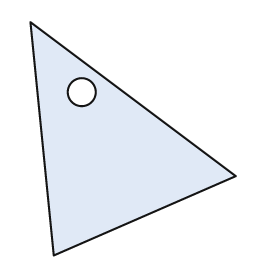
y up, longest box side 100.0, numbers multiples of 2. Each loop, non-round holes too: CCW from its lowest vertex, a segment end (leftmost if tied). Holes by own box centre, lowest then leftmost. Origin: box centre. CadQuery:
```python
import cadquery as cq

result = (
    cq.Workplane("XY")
    .moveTo(-34.0, -50.0)
    .lineTo(44.0, -16.0)
    .lineTo(-44.0, 50.0)
    .close()
    .moveTo(-22.0, 20.0)
    .circle(6.0)
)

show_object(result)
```